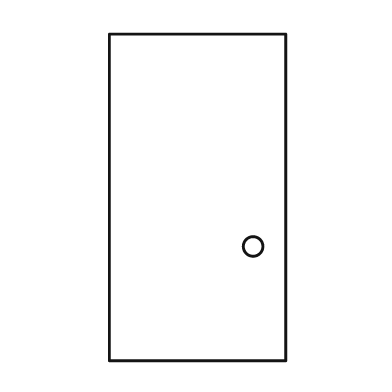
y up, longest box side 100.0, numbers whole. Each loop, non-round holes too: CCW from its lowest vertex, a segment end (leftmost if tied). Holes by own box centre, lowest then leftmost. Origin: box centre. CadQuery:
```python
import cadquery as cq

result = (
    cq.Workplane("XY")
    .moveTo(-27.0, -50.0)
    .lineTo(27.0, -50.0)
    .lineTo(27.0, 50.0)
    .lineTo(-27.0, 50.0)
    .close()
    .moveTo(17.0, -15.0)
    .circle(3.0)
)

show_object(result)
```